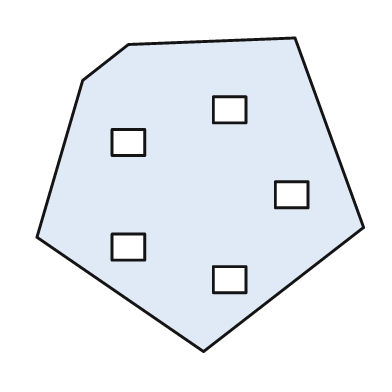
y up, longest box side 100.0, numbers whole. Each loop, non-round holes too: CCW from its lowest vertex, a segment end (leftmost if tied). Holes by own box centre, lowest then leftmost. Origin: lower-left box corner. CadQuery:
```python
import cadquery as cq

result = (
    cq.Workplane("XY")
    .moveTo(51.0, 0.0)
    .lineTo(100.0, 38.0)
    .lineTo(79.0, 96.0)
    .lineTo(28.0, 94.0)
    .lineTo(14.0, 83.0)
    .lineTo(0.0, 35.0)
    .close()
    .moveTo(54.0, 18.0)
    .lineTo(64.0, 18.0)
    .lineTo(64.0, 26.0)
    .lineTo(54.0, 26.0)
    .close()
    .moveTo(23.0, 28.0)
    .lineTo(33.0, 28.0)
    .lineTo(33.0, 36.0)
    .lineTo(23.0, 36.0)
    .close()
    .moveTo(73.0, 44.0)
    .lineTo(83.0, 44.0)
    .lineTo(83.0, 52.0)
    .lineTo(73.0, 52.0)
    .close()
    .moveTo(23.0, 60.0)
    .lineTo(33.0, 60.0)
    .lineTo(33.0, 68.0)
    .lineTo(23.0, 68.0)
    .close()
    .moveTo(54.0, 70.0)
    .lineTo(64.0, 70.0)
    .lineTo(64.0, 78.0)
    .lineTo(54.0, 78.0)
    .close()
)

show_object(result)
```